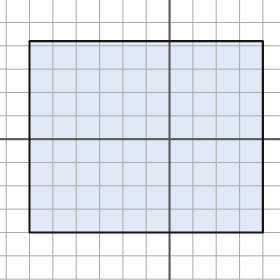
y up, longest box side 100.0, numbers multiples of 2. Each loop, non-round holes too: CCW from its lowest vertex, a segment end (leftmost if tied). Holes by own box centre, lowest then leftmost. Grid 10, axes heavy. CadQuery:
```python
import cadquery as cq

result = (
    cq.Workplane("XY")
    .moveTo(-60.0, -40.0)
    .lineTo(40.0, -40.0)
    .lineTo(40.0, 42.0)
    .lineTo(-60.0, 42.0)
    .close()
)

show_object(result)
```